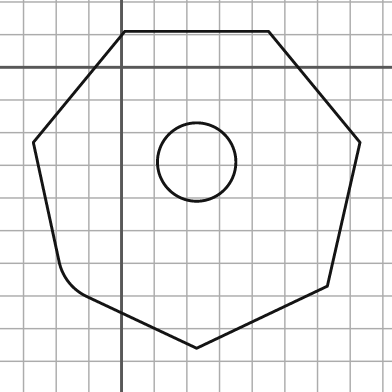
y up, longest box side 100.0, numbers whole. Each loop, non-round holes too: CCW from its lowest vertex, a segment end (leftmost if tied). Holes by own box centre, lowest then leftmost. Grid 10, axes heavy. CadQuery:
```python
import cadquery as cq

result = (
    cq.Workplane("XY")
    .moveTo(23.0, -86.0)
    .lineTo(63.0, -67.0)
    .lineTo(73.0, -23.0)
    .lineTo(45.0, 11.0)
    .lineTo(1.0, 11.0)
    .lineTo(-27.0, -23.0)
    .lineTo(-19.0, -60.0)
    .threePointArc((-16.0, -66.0), (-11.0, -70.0))
    .close()
    .moveTo(23.0, -29.0)
    .circle(12.0)
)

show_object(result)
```